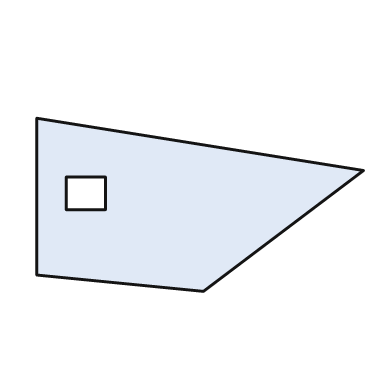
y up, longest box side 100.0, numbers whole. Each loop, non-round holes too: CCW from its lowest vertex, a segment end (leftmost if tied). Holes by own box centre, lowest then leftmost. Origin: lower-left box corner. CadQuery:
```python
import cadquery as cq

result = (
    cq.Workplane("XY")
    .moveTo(51.0, 0.0)
    .lineTo(100.0, 37.0)
    .lineTo(0.0, 53.0)
    .lineTo(0.0, 5.0)
    .close()
    .moveTo(9.0, 25.0)
    .lineTo(21.0, 25.0)
    .lineTo(21.0, 35.0)
    .lineTo(9.0, 35.0)
    .close()
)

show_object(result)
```